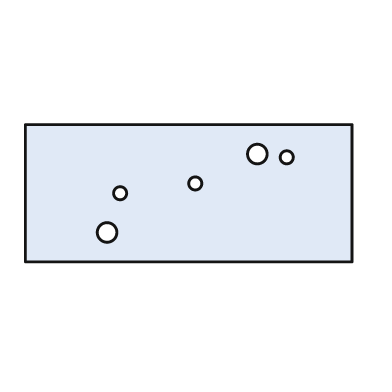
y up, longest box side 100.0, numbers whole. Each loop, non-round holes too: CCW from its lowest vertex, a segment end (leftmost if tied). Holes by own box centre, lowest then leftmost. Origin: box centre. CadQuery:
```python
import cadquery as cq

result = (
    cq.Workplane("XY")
    .moveTo(-50.0, -21.0)
    .lineTo(50.0, -21.0)
    .lineTo(50.0, 21.0)
    .lineTo(-50.0, 21.0)
    .close()
    .moveTo(-25.0, -12.0)
    .circle(3.0)
    .moveTo(-21.0, 0.0)
    .circle(2.0)
    .moveTo(2.0, 3.0)
    .circle(2.0)
    .moveTo(30.0, 11.0)
    .circle(2.0)
    .moveTo(21.0, 12.0)
    .circle(3.0)
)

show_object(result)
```